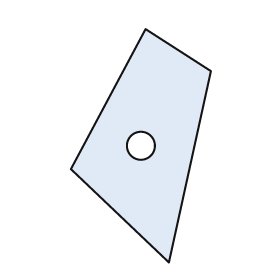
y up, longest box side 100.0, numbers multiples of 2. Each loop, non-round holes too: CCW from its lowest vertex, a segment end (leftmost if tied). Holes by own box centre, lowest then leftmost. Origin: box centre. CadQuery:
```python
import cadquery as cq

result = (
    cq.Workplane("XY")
    .moveTo(12.0, -50.0)
    .lineTo(30.0, 32.0)
    .lineTo(2.0, 50.0)
    .lineTo(-30.0, -10.0)
    .close()
    .moveTo(0.0, 0.0)
    .circle(6.0)
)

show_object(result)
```